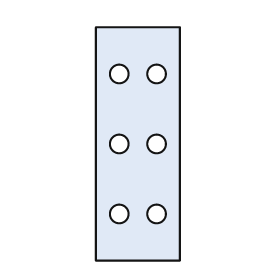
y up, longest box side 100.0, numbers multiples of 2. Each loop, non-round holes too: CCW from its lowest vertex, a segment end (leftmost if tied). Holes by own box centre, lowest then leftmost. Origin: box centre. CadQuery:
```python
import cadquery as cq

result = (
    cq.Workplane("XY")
    .moveTo(-18.0, -50.0)
    .lineTo(18.0, -50.0)
    .lineTo(18.0, 50.0)
    .lineTo(-18.0, 50.0)
    .close()
    .moveTo(-8.0, -30.0)
    .circle(4.0)
    .moveTo(8.0, -30.0)
    .circle(4.0)
    .moveTo(-8.0, 0.0)
    .circle(4.0)
    .moveTo(8.0, 0.0)
    .circle(4.0)
    .moveTo(-8.0, 30.0)
    .circle(4.0)
    .moveTo(8.0, 30.0)
    .circle(4.0)
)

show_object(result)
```